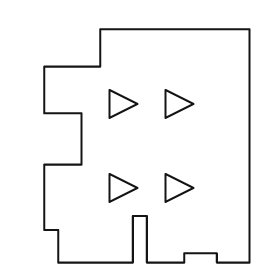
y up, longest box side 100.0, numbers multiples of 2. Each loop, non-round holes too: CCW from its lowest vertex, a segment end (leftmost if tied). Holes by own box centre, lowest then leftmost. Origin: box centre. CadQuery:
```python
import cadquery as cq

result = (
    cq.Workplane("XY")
    .moveTo(-38.0, -50.0)
    .lineTo(-6.0, -50.0)
    .lineTo(-6.0, -30.0)
    .lineTo(0.0, -30.0)
    .lineTo(0.0, -50.0)
    .lineTo(16.0, -50.0)
    .lineTo(16.0, -46.0)
    .lineTo(30.0, -46.0)
    .lineTo(30.0, -50.0)
    .lineTo(44.0, -50.0)
    .lineTo(44.0, 50.0)
    .lineTo(-20.0, 50.0)
    .lineTo(-20.0, 34.0)
    .lineTo(-44.0, 34.0)
    .lineTo(-44.0, 14.0)
    .lineTo(-28.0, 14.0)
    .lineTo(-28.0, -8.0)
    .lineTo(-44.0, -8.0)
    .lineTo(-44.0, -36.0)
    .lineTo(-38.0, -36.0)
    .close()
    .moveTo(-16.0, -24.0)
    .lineTo(-4.0, -18.0)
    .lineTo(-16.0, -12.0)
    .close()
    .moveTo(8.0, -24.0)
    .lineTo(20.0, -18.0)
    .lineTo(8.0, -12.0)
    .close()
    .moveTo(-16.0, 12.0)
    .lineTo(-4.0, 18.0)
    .lineTo(-16.0, 24.0)
    .close()
    .moveTo(8.0, 12.0)
    .lineTo(20.0, 18.0)
    .lineTo(8.0, 24.0)
    .close()
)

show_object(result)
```